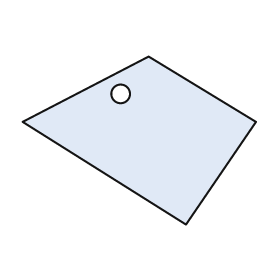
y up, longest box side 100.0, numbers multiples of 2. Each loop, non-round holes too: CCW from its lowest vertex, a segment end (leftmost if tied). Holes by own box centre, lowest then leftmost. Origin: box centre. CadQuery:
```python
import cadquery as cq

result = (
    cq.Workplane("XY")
    .moveTo(20.0, -36.0)
    .lineTo(50.0, 8.0)
    .lineTo(4.0, 36.0)
    .lineTo(-50.0, 8.0)
    .close()
    .moveTo(-8.0, 20.0)
    .circle(4.0)
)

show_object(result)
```